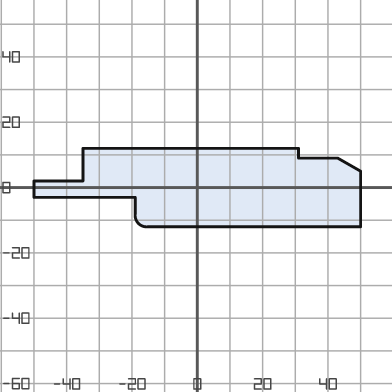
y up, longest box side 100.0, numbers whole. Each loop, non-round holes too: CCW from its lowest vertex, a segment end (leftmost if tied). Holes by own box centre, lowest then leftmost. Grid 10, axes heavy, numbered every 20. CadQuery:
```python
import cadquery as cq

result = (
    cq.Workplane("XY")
    .moveTo(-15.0, -12.0)
    .lineTo(50.0, -12.0)
    .lineTo(50.0, 5.0)
    .lineTo(43.0, 9.0)
    .lineTo(31.0, 9.0)
    .lineTo(31.0, 12.0)
    .lineTo(-35.0, 12.0)
    .lineTo(-35.0, 2.0)
    .lineTo(-50.0, 2.0)
    .lineTo(-50.0, -3.0)
    .lineTo(-19.0, -3.0)
    .lineTo(-19.0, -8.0)
    .threePointArc((-18.0, -11.0), (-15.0, -12.0))
    .close()
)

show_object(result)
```